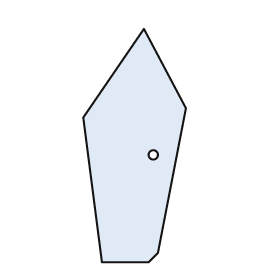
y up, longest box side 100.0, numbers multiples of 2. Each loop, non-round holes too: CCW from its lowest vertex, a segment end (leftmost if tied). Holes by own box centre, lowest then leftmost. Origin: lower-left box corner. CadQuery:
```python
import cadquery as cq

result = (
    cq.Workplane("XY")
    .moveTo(8.0, 0.0)
    .lineTo(28.0, 0.0)
    .lineTo(32.0, 4.0)
    .lineTo(44.0, 66.0)
    .lineTo(26.0, 100.0)
    .lineTo(0.0, 62.0)
    .close()
    .moveTo(30.0, 46.0)
    .circle(2.0)
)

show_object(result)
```